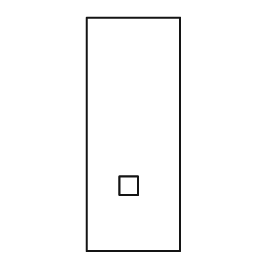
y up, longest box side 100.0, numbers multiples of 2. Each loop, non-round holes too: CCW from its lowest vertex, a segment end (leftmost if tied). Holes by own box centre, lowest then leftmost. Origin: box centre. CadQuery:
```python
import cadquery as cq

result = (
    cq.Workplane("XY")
    .moveTo(-20.0, -50.0)
    .lineTo(20.0, -50.0)
    .lineTo(20.0, 50.0)
    .lineTo(-20.0, 50.0)
    .close()
    .moveTo(-6.0, -26.0)
    .lineTo(2.0, -26.0)
    .lineTo(2.0, -18.0)
    .lineTo(-6.0, -18.0)
    .close()
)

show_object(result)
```